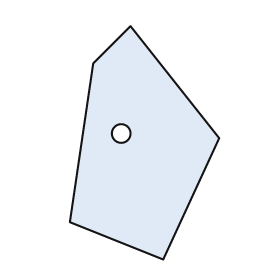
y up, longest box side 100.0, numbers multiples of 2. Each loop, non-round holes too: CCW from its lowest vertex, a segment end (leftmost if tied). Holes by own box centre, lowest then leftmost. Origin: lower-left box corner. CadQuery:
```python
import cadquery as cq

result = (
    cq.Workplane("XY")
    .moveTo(40.0, 0.0)
    .lineTo(64.0, 52.0)
    .lineTo(26.0, 100.0)
    .lineTo(10.0, 84.0)
    .lineTo(0.0, 16.0)
    .close()
    .moveTo(22.0, 54.0)
    .circle(4.0)
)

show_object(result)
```